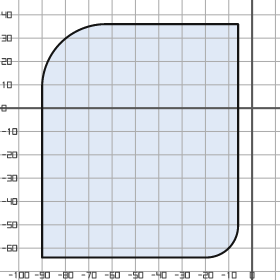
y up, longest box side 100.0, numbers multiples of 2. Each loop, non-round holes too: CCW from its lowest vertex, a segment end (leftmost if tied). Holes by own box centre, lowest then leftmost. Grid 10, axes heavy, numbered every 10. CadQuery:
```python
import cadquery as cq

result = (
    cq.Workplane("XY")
    .moveTo(-90.0, -64.0)
    .lineTo(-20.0, -64.0)
    .threePointArc((-10.0, -60.0), (-6.0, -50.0))
    .lineTo(-6.0, 36.0)
    .lineTo(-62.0, 36.0)
    .threePointArc((-82.0, 28.0), (-90.0, 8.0))
    .close()
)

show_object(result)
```